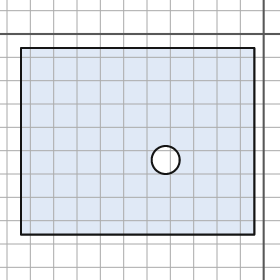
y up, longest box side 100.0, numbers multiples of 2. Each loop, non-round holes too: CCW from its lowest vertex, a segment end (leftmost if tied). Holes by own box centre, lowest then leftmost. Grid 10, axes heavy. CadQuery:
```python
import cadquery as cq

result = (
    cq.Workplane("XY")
    .moveTo(-104.0, -86.0)
    .lineTo(-4.0, -86.0)
    .lineTo(-4.0, -6.0)
    .lineTo(-104.0, -6.0)
    .close()
    .moveTo(-42.0, -54.0)
    .circle(6.0)
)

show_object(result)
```